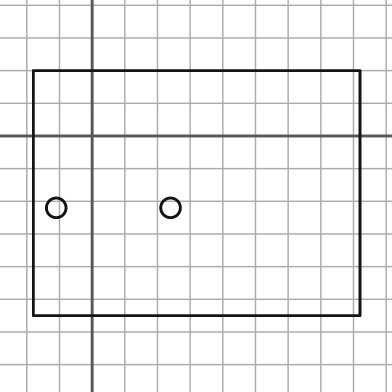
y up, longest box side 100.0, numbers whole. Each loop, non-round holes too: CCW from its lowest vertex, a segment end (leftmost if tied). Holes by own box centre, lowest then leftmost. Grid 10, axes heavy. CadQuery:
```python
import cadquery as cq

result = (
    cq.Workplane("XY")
    .moveTo(-18.0, -55.0)
    .lineTo(82.0, -55.0)
    .lineTo(82.0, 20.0)
    .lineTo(-18.0, 20.0)
    .close()
    .moveTo(-11.0, -22.0)
    .circle(3.0)
    .moveTo(24.0, -22.0)
    .circle(3.0)
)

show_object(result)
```